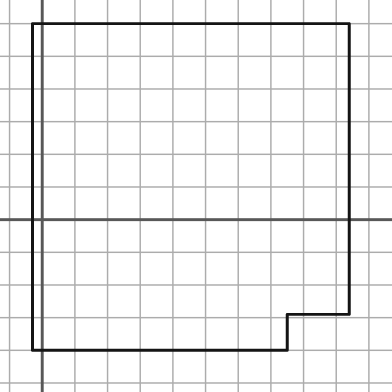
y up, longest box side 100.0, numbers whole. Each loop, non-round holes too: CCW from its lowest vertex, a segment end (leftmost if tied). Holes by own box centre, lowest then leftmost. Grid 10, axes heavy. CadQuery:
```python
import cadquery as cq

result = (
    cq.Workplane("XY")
    .moveTo(-3.0, -40.0)
    .lineTo(75.0, -40.0)
    .lineTo(75.0, -29.0)
    .lineTo(94.0, -29.0)
    .lineTo(94.0, 60.0)
    .lineTo(-3.0, 60.0)
    .close()
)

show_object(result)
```